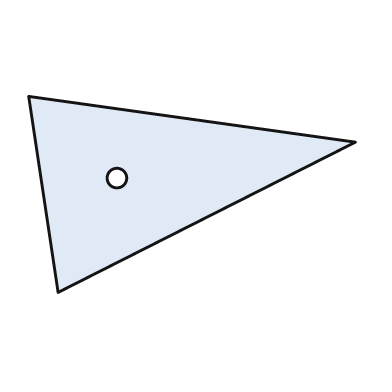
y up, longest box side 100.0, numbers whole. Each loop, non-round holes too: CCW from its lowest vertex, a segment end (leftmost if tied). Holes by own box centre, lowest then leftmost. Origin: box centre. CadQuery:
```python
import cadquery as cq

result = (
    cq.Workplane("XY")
    .moveTo(-41.0, -30.0)
    .lineTo(50.0, 16.0)
    .lineTo(-50.0, 30.0)
    .close()
    .moveTo(-23.0, 5.0)
    .circle(3.0)
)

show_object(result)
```